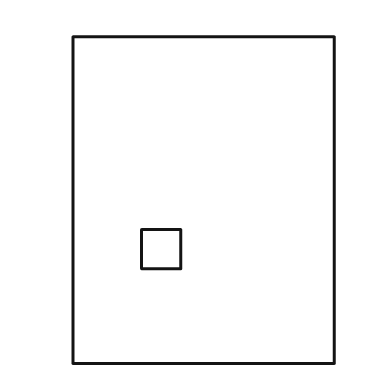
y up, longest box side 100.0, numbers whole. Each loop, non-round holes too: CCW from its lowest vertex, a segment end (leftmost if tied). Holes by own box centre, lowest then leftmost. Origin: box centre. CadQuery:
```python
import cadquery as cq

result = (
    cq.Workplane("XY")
    .moveTo(-40.0, -50.0)
    .lineTo(40.0, -50.0)
    .lineTo(40.0, 50.0)
    .lineTo(-40.0, 50.0)
    .close()
    .moveTo(-19.0, -21.0)
    .lineTo(-7.0, -21.0)
    .lineTo(-7.0, -9.0)
    .lineTo(-19.0, -9.0)
    .close()
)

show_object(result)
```